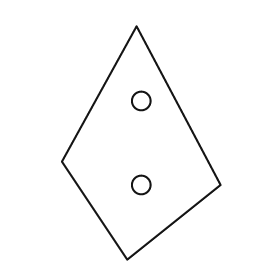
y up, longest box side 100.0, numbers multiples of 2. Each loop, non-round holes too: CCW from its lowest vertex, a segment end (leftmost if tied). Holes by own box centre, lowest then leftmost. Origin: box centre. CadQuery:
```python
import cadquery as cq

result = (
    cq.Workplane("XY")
    .moveTo(-6.0, -50.0)
    .lineTo(34.0, -18.0)
    .lineTo(-2.0, 50.0)
    .lineTo(-34.0, -8.0)
    .close()
    .moveTo(0.0, -18.0)
    .circle(4.0)
    .moveTo(0.0, 18.0)
    .circle(4.0)
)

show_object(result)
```